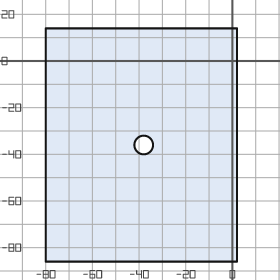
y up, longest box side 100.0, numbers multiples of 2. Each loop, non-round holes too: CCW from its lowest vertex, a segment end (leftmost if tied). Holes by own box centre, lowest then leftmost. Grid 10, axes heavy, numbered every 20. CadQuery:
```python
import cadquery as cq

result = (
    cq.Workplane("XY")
    .moveTo(-80.0, -86.0)
    .lineTo(2.0, -86.0)
    .lineTo(2.0, 14.0)
    .lineTo(-80.0, 14.0)
    .close()
    .moveTo(-38.0, -36.0)
    .circle(4.0)
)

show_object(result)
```